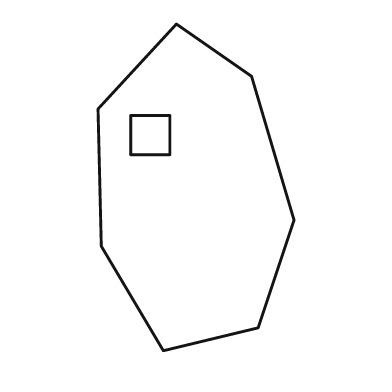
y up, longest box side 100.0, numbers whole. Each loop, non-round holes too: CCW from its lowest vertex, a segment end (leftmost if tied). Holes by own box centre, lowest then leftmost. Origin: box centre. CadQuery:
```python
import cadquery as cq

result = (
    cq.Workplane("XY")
    .moveTo(-10.0, -50.0)
    .lineTo(19.0, -43.0)
    .lineTo(30.0, -10.0)
    .lineTo(17.0, 34.0)
    .lineTo(-6.0, 50.0)
    .lineTo(-30.0, 24.0)
    .lineTo(-29.0, -18.0)
    .close()
    .moveTo(-20.0, 10.0)
    .lineTo(-8.0, 10.0)
    .lineTo(-8.0, 22.0)
    .lineTo(-20.0, 22.0)
    .close()
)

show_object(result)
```